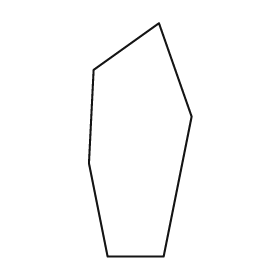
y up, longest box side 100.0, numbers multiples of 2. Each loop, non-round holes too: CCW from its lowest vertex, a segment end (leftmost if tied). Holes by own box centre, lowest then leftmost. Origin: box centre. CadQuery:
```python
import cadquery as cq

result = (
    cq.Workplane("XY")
    .moveTo(-14.0, -50.0)
    .lineTo(10.0, -50.0)
    .lineTo(22.0, 10.0)
    .lineTo(8.0, 50.0)
    .lineTo(-20.0, 30.0)
    .lineTo(-22.0, -10.0)
    .close()
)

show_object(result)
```